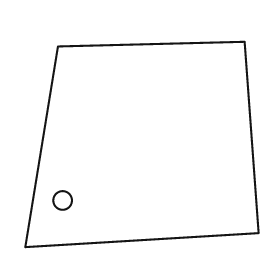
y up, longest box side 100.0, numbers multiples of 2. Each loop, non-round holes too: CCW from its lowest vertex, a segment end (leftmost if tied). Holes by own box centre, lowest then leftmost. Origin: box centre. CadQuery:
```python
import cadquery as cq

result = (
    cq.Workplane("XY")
    .moveTo(-50.0, -44.0)
    .lineTo(50.0, -38.0)
    .lineTo(44.0, 44.0)
    .lineTo(-36.0, 42.0)
    .close()
    .moveTo(-34.0, -24.0)
    .circle(4.0)
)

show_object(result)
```